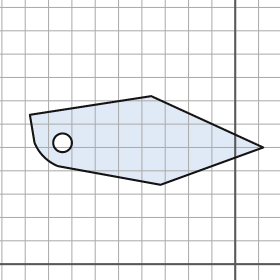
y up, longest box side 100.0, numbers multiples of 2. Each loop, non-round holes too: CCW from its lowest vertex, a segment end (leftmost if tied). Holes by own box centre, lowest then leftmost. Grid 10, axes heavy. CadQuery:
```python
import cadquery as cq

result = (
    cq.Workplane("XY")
    .moveTo(-32.0, 34.0)
    .lineTo(12.0, 50.0)
    .lineTo(-36.0, 72.0)
    .lineTo(-88.0, 64.0)
    .lineTo(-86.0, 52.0)
    .threePointArc((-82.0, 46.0), (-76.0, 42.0))
    .close()
    .moveTo(-74.0, 52.0)
    .circle(4.0)
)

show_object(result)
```